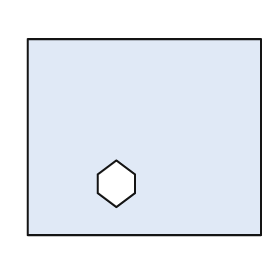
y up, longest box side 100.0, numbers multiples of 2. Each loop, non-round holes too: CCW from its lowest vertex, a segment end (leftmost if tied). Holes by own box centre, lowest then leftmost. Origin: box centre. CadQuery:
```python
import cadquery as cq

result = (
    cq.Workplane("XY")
    .moveTo(-50.0, -42.0)
    .lineTo(50.0, -42.0)
    .lineTo(50.0, 42.0)
    .lineTo(-50.0, 42.0)
    .close()
    .moveTo(-12.0, -30.0)
    .lineTo(-4.0, -24.0)
    .lineTo(-4.0, -16.0)
    .lineTo(-12.0, -10.0)
    .lineTo(-20.0, -16.0)
    .lineTo(-20.0, -24.0)
    .close()
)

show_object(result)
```